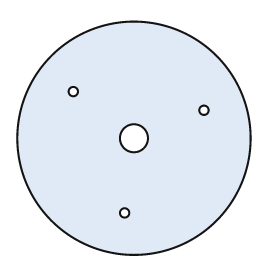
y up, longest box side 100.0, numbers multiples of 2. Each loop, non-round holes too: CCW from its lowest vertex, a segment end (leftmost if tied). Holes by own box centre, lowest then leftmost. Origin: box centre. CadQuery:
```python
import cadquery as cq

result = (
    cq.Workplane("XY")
    .moveTo(0.0, 0.0)
    .circle(50.0)
    .moveTo(-4.0, -32.0)
    .circle(2.0)
    .moveTo(0.0, 0.0)
    .circle(6.0)
    .moveTo(30.0, 12.0)
    .circle(2.0)
    .moveTo(-26.0, 20.0)
    .circle(2.0)
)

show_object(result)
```